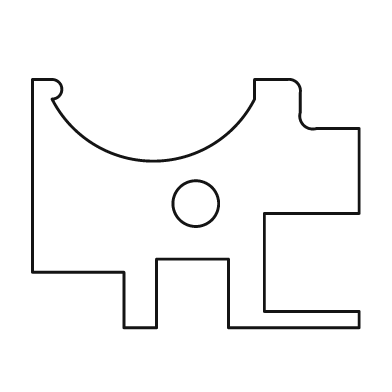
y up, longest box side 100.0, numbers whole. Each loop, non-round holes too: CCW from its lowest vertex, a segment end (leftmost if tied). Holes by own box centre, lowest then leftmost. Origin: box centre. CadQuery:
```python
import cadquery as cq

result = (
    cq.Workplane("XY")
    .moveTo(-22.0, -38.0)
    .lineTo(-12.0, -38.0)
    .lineTo(-12.0, -17.0)
    .lineTo(10.0, -17.0)
    .lineTo(10.0, -38.0)
    .lineTo(50.0, -38.0)
    .lineTo(50.0, -33.0)
    .lineTo(21.0, -33.0)
    .lineTo(21.0, -3.0)
    .lineTo(50.0, -3.0)
    .lineTo(50.0, 23.0)
    .lineTo(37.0, 23.0)
    .threePointArc((33.0, 24.0), (32.0, 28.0))
    .lineTo(32.0, 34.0)
    .threePointArc((31.0, 37.0), (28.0, 38.0))
    .lineTo(18.0, 38.0)
    .lineTo(18.0, 32.0)
    .threePointArc((-13.0, 13.0), (-44.0, 32.0))
    .threePointArc((-41.0, 35.0), (-44.0, 38.0))
    .lineTo(-50.0, 38.0)
    .lineTo(-50.0, -21.0)
    .lineTo(-22.0, -21.0)
    .close()
    .moveTo(0.0, 0.0)
    .circle(7.0)
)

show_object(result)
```